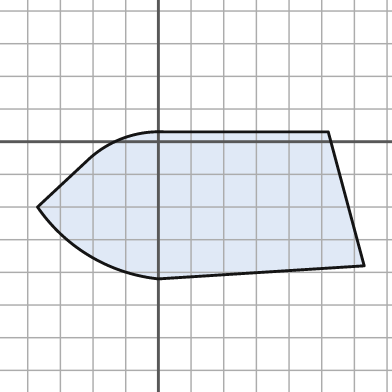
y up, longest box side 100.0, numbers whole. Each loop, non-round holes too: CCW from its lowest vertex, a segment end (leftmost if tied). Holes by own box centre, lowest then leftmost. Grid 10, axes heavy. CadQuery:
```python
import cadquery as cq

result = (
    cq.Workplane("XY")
    .moveTo(0.0, -42.0)
    .lineTo(63.0, -38.0)
    .lineTo(52.0, 3.0)
    .lineTo(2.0, 3.0)
    .threePointArc((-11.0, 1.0), (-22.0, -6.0))
    .lineTo(-37.0, -20.0)
    .threePointArc((-21.0, -35.0), (0.0, -42.0))
    .close()
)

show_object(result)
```